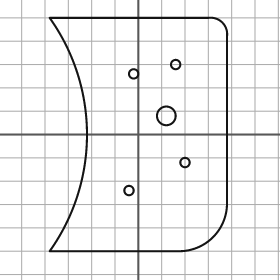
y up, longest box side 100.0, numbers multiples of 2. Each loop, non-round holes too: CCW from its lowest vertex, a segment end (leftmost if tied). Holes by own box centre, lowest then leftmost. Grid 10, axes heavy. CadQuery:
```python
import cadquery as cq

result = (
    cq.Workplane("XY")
    .moveTo(-38.0, -50.0)
    .lineTo(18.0, -50.0)
    .threePointArc((32.0, -44.0), (38.0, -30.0))
    .lineTo(38.0, 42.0)
    .threePointArc((36.0, 48.0), (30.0, 50.0))
    .lineTo(-38.0, 50.0)
    .threePointArc((-22.0, 0.0), (-38.0, -50.0))
    .close()
    .moveTo(-4.0, -24.0)
    .circle(2.0)
    .moveTo(20.0, -12.0)
    .circle(2.0)
    .moveTo(12.0, 8.0)
    .circle(4.0)
    .moveTo(-2.0, 26.0)
    .circle(2.0)
    .moveTo(16.0, 30.0)
    .circle(2.0)
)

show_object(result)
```